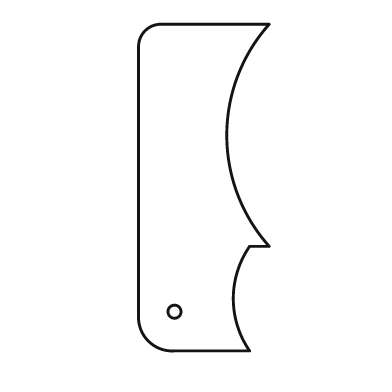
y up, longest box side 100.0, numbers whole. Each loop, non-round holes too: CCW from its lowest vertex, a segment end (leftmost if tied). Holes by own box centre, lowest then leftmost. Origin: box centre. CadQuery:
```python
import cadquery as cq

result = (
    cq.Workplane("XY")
    .moveTo(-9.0, -50.0)
    .lineTo(14.0, -50.0)
    .threePointArc((9.0, -34.0), (14.0, -18.0))
    .lineTo(20.0, -18.0)
    .threePointArc((7.0, 16.0), (20.0, 50.0))
    .lineTo(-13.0, 50.0)
    .threePointArc((-18.0, 48.0), (-20.0, 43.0))
    .lineTo(-20.0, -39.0)
    .threePointArc((-17.0, -47.0), (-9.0, -50.0))
    .close()
    .moveTo(-9.0, -38.0)
    .circle(2.0)
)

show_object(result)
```